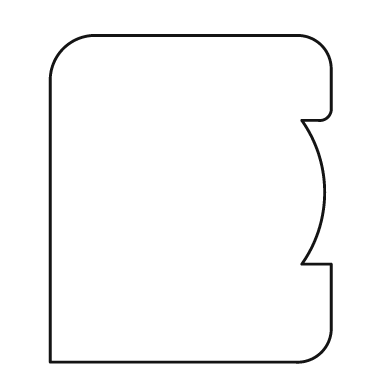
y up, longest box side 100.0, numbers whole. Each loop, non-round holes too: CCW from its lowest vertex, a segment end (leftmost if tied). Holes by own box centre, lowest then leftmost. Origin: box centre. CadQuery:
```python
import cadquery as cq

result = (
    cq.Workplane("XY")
    .moveTo(-43.0, -50.0)
    .lineTo(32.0, -50.0)
    .threePointArc((40.0, -47.0), (43.0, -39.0))
    .lineTo(43.0, -20.0)
    .lineTo(34.0, -20.0)
    .threePointArc((41.0, 2.0), (34.0, 24.0))
    .lineTo(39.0, 24.0)
    .threePointArc((42.0, 25.0), (43.0, 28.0))
    .lineTo(43.0, 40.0)
    .threePointArc((40.0, 47.0), (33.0, 50.0))
    .lineTo(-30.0, 50.0)
    .threePointArc((-39.0, 46.0), (-43.0, 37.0))
    .close()
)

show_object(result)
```